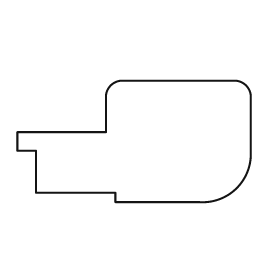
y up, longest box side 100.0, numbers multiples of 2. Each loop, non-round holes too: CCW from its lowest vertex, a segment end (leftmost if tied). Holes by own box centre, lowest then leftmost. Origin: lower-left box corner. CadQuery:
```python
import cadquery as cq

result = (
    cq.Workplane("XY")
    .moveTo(42.0, 0.0)
    .lineTo(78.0, 0.0)
    .threePointArc((94.0, 6.0), (100.0, 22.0))
    .lineTo(100.0, 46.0)
    .threePointArc((98.0, 50.0), (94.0, 52.0))
    .lineTo(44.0, 52.0)
    .threePointArc((40.0, 50.0), (38.0, 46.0))
    .lineTo(38.0, 30.0)
    .lineTo(0.0, 30.0)
    .lineTo(0.0, 22.0)
    .lineTo(8.0, 22.0)
    .lineTo(8.0, 4.0)
    .lineTo(42.0, 4.0)
    .close()
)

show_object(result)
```